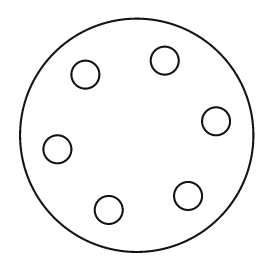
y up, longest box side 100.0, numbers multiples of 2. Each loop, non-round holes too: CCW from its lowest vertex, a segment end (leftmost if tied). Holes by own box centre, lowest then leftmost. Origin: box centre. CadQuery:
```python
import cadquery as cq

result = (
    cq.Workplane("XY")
    .moveTo(0.0, 0.0)
    .circle(50.0)
    .moveTo(-12.0, -32.0)
    .circle(6.0)
    .moveTo(22.0, -26.0)
    .circle(6.0)
    .moveTo(-34.0, -6.0)
    .circle(6.0)
    .moveTo(34.0, 6.0)
    .circle(6.0)
    .moveTo(-22.0, 26.0)
    .circle(6.0)
    .moveTo(12.0, 32.0)
    .circle(6.0)
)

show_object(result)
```